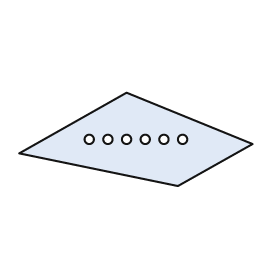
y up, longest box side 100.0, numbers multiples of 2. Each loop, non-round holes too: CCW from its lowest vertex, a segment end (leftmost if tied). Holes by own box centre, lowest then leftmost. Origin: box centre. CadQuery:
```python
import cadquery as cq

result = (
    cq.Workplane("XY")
    .moveTo(18.0, -20.0)
    .lineTo(50.0, -2.0)
    .lineTo(-4.0, 20.0)
    .lineTo(-50.0, -6.0)
    .close()
    .moveTo(-20.0, 0.0)
    .circle(2.0)
    .moveTo(-12.0, 0.0)
    .circle(2.0)
    .moveTo(-4.0, 0.0)
    .circle(2.0)
    .moveTo(4.0, 0.0)
    .circle(2.0)
    .moveTo(12.0, 0.0)
    .circle(2.0)
    .moveTo(20.0, 0.0)
    .circle(2.0)
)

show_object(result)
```